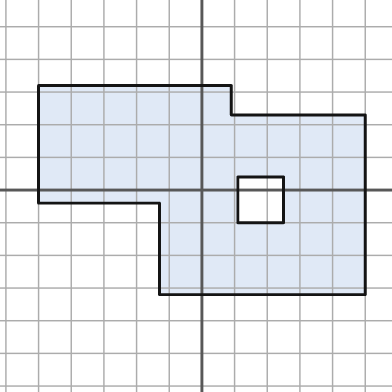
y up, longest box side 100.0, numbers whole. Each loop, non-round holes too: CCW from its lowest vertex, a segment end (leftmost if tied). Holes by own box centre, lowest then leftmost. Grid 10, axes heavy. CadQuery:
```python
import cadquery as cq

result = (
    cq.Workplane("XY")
    .moveTo(-13.0, -32.0)
    .lineTo(50.0, -32.0)
    .lineTo(50.0, 23.0)
    .lineTo(9.0, 23.0)
    .lineTo(9.0, 32.0)
    .lineTo(-50.0, 32.0)
    .lineTo(-50.0, -4.0)
    .lineTo(-13.0, -4.0)
    .close()
    .moveTo(11.0, -10.0)
    .lineTo(25.0, -10.0)
    .lineTo(25.0, 4.0)
    .lineTo(11.0, 4.0)
    .close()
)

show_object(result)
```